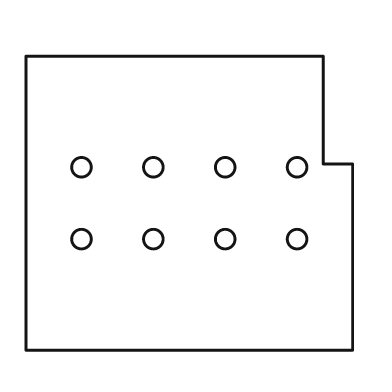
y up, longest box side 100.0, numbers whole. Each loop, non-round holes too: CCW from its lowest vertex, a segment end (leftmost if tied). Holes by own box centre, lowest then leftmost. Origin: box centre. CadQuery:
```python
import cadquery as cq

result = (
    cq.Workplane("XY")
    .moveTo(-50.0, -45.0)
    .lineTo(50.0, -45.0)
    .lineTo(50.0, 12.0)
    .lineTo(41.0, 12.0)
    .lineTo(41.0, 45.0)
    .lineTo(-50.0, 45.0)
    .close()
    .moveTo(-33.0, -11.0)
    .circle(3.0)
    .moveTo(-11.0, -11.0)
    .circle(3.0)
    .moveTo(11.0, -11.0)
    .circle(3.0)
    .moveTo(33.0, -11.0)
    .circle(3.0)
    .moveTo(-33.0, 11.0)
    .circle(3.0)
    .moveTo(-11.0, 11.0)
    .circle(3.0)
    .moveTo(11.0, 11.0)
    .circle(3.0)
    .moveTo(33.0, 11.0)
    .circle(3.0)
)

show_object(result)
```